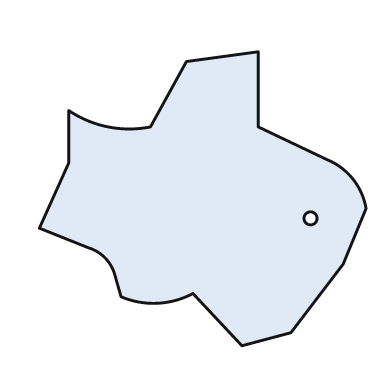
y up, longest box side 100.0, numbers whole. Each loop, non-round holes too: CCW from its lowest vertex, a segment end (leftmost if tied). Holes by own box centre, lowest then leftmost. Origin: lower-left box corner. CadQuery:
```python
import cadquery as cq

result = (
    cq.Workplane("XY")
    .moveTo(62.0, 0.0)
    .lineTo(77.0, 4.0)
    .lineTo(93.0, 25.0)
    .lineTo(100.0, 42.0)
    .threePointArc((96.0, 51.0), (88.0, 57.0))
    .lineTo(67.0, 67.0)
    .lineTo(67.0, 90.0)
    .lineTo(45.0, 87.0)
    .lineTo(34.0, 67.0)
    .threePointArc((21.0, 67.0), (9.0, 72.0))
    .lineTo(9.0, 56.0)
    .lineTo(0.0, 36.0)
    .lineTo(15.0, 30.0)
    .threePointArc((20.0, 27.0), (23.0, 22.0))
    .lineTo(25.0, 15.0)
    .threePointArc((36.0, 13.0), (47.0, 16.0))
    .close()
    .moveTo(83.0, 39.0)
    .circle(2.0)
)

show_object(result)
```